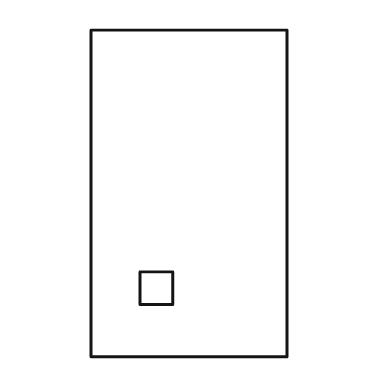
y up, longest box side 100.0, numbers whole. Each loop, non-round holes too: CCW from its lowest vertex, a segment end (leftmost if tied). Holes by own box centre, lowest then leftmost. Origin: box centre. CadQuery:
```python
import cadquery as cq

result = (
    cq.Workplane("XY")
    .moveTo(-30.0, -50.0)
    .lineTo(30.0, -50.0)
    .lineTo(30.0, 50.0)
    .lineTo(-30.0, 50.0)
    .close()
    .moveTo(-15.0, -34.0)
    .lineTo(-5.0, -34.0)
    .lineTo(-5.0, -24.0)
    .lineTo(-15.0, -24.0)
    .close()
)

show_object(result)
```